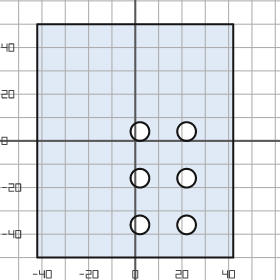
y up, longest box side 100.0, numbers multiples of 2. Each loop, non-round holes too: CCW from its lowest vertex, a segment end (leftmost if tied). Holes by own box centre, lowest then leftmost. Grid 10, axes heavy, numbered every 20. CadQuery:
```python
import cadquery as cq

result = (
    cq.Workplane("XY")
    .moveTo(-42.0, -50.0)
    .lineTo(42.0, -50.0)
    .lineTo(42.0, 50.0)
    .lineTo(-42.0, 50.0)
    .close()
    .moveTo(2.0, -36.0)
    .circle(4.0)
    .moveTo(22.0, -36.0)
    .circle(4.0)
    .moveTo(2.0, -16.0)
    .circle(4.0)
    .moveTo(22.0, -16.0)
    .circle(4.0)
    .moveTo(2.0, 4.0)
    .circle(4.0)
    .moveTo(22.0, 4.0)
    .circle(4.0)
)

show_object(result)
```